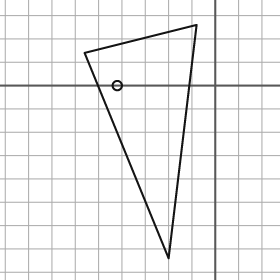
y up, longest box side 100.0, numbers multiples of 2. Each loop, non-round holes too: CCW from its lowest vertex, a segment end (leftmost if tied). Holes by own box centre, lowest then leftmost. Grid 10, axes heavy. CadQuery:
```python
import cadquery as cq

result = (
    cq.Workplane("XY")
    .moveTo(-20.0, -74.0)
    .lineTo(-8.0, 26.0)
    .lineTo(-56.0, 14.0)
    .close()
    .moveTo(-42.0, 0.0)
    .circle(2.0)
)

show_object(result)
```